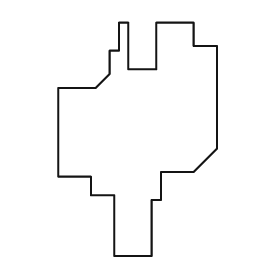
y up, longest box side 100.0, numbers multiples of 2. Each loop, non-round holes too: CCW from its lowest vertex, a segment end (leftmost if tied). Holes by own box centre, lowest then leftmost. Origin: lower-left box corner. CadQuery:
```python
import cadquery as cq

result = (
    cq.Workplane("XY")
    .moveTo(24.0, 0.0)
    .lineTo(40.0, 0.0)
    .lineTo(40.0, 24.0)
    .lineTo(44.0, 24.0)
    .lineTo(44.0, 36.0)
    .lineTo(58.0, 36.0)
    .lineTo(68.0, 46.0)
    .lineTo(68.0, 90.0)
    .lineTo(58.0, 90.0)
    .lineTo(58.0, 100.0)
    .lineTo(42.0, 100.0)
    .lineTo(42.0, 80.0)
    .lineTo(30.0, 80.0)
    .lineTo(30.0, 100.0)
    .lineTo(26.0, 100.0)
    .lineTo(26.0, 88.0)
    .lineTo(22.0, 88.0)
    .lineTo(22.0, 78.0)
    .lineTo(16.0, 72.0)
    .lineTo(0.0, 72.0)
    .lineTo(0.0, 34.0)
    .lineTo(14.0, 34.0)
    .lineTo(14.0, 26.0)
    .lineTo(24.0, 26.0)
    .close()
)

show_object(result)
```